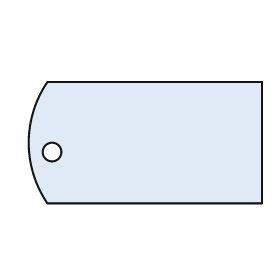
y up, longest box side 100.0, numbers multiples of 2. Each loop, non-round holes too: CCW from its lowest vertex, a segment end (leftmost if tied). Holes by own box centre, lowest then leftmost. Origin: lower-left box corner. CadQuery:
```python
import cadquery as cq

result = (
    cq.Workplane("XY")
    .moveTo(8.0, 0.0)
    .lineTo(100.0, 0.0)
    .lineTo(100.0, 52.0)
    .lineTo(8.0, 52.0)
    .threePointArc((0.0, 26.0), (8.0, 0.0))
    .close()
    .moveTo(10.0, 22.0)
    .circle(4.0)
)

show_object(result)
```